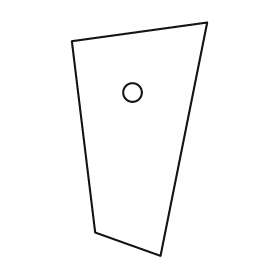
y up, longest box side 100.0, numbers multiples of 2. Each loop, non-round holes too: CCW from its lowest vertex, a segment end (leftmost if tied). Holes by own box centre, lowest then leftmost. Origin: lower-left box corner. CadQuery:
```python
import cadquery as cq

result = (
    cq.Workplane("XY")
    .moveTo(38.0, 0.0)
    .lineTo(58.0, 100.0)
    .lineTo(0.0, 92.0)
    .lineTo(10.0, 10.0)
    .close()
    .moveTo(26.0, 70.0)
    .circle(4.0)
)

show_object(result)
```